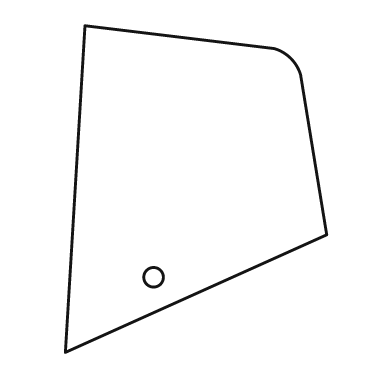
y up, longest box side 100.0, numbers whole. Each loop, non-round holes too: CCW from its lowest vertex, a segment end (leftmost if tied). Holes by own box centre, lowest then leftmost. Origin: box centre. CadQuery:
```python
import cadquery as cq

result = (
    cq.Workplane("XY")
    .moveTo(-40.0, -50.0)
    .lineTo(40.0, -14.0)
    .lineTo(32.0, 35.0)
    .threePointArc((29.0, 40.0), (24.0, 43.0))
    .lineTo(-34.0, 50.0)
    .close()
    .moveTo(-13.0, -27.0)
    .circle(3.0)
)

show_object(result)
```